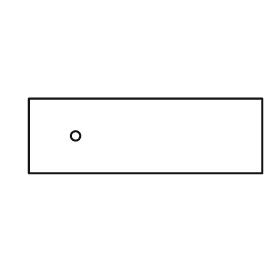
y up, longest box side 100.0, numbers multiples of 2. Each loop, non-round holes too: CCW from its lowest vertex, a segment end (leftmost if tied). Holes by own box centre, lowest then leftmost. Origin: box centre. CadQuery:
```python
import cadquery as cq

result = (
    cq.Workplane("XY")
    .moveTo(-50.0, -16.0)
    .lineTo(50.0, -16.0)
    .lineTo(50.0, 16.0)
    .lineTo(-50.0, 16.0)
    .close()
    .moveTo(-30.0, 0.0)
    .circle(2.0)
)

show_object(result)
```